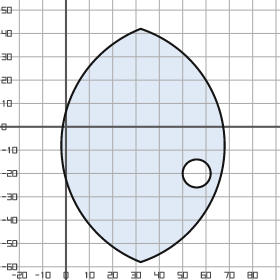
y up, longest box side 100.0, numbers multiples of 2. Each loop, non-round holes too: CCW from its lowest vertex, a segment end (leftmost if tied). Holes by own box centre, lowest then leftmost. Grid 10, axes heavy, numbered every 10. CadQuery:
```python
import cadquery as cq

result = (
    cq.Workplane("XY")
    .moveTo(32.0, -58.0)
    .threePointArc((68.0, -8.0), (32.0, 42.0))
    .threePointArc((-2.0, -8.0), (32.0, -58.0))
    .close()
    .moveTo(56.0, -20.0)
    .circle(6.0)
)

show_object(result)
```